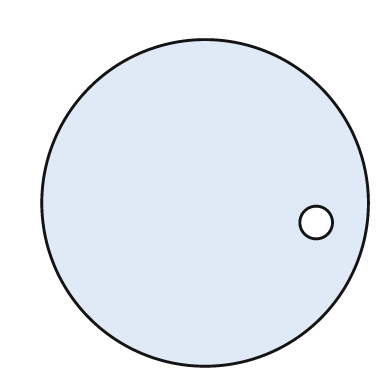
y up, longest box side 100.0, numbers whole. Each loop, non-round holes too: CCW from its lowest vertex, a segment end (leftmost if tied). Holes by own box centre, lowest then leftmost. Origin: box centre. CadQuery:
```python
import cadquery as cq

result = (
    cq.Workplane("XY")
    .moveTo(0.0, 0.0)
    .circle(50.0)
    .moveTo(34.0, -6.0)
    .circle(5.0)
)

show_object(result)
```